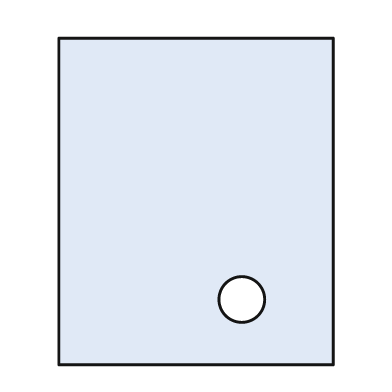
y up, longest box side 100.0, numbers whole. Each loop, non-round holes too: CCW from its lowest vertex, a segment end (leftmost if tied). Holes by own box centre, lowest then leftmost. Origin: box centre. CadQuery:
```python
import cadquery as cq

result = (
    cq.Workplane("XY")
    .moveTo(-42.0, -50.0)
    .lineTo(42.0, -50.0)
    .lineTo(42.0, 50.0)
    .lineTo(-42.0, 50.0)
    .close()
    .moveTo(14.0, -30.0)
    .circle(7.0)
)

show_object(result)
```